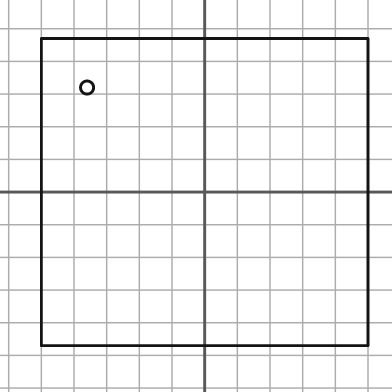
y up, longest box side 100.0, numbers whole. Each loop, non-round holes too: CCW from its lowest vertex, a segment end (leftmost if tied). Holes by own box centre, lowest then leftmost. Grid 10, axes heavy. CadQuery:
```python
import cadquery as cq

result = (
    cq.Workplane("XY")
    .moveTo(-50.0, -47.0)
    .lineTo(50.0, -47.0)
    .lineTo(50.0, 47.0)
    .lineTo(-50.0, 47.0)
    .close()
    .moveTo(-36.0, 32.0)
    .circle(2.0)
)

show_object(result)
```